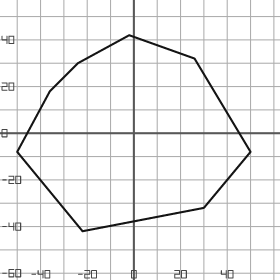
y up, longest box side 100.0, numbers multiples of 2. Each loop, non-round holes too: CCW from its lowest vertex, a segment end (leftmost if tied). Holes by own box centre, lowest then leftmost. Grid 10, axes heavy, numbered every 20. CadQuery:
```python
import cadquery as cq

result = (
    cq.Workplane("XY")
    .moveTo(-22.0, -42.0)
    .lineTo(30.0, -32.0)
    .lineTo(50.0, -8.0)
    .lineTo(26.0, 32.0)
    .lineTo(-2.0, 42.0)
    .lineTo(-24.0, 30.0)
    .lineTo(-36.0, 18.0)
    .lineTo(-50.0, -8.0)
    .close()
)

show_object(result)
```